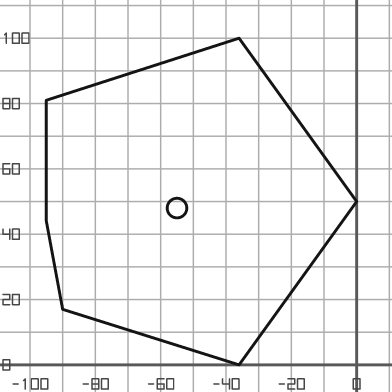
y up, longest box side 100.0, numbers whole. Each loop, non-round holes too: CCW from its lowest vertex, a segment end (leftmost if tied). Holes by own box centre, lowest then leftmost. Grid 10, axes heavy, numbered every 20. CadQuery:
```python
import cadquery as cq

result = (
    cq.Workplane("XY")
    .moveTo(-36.0, 0.0)
    .lineTo(0.0, 50.0)
    .lineTo(-36.0, 100.0)
    .lineTo(-95.0, 81.0)
    .lineTo(-95.0, 44.0)
    .lineTo(-90.0, 17.0)
    .close()
    .moveTo(-55.0, 48.0)
    .circle(3.0)
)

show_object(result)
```